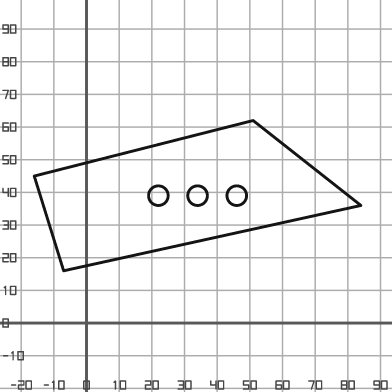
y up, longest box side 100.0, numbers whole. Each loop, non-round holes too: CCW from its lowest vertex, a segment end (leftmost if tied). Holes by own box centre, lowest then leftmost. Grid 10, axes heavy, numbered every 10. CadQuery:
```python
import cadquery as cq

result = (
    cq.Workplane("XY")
    .moveTo(-7.0, 16.0)
    .lineTo(84.0, 36.0)
    .lineTo(51.0, 62.0)
    .lineTo(-16.0, 45.0)
    .close()
    .moveTo(22.0, 39.0)
    .circle(3.0)
    .moveTo(34.0, 39.0)
    .circle(3.0)
    .moveTo(46.0, 39.0)
    .circle(3.0)
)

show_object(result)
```